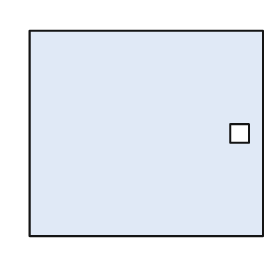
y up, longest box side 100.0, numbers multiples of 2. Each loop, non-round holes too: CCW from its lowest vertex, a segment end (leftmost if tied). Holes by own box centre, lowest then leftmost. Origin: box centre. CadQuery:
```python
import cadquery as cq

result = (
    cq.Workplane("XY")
    .moveTo(-50.0, -44.0)
    .lineTo(50.0, -44.0)
    .lineTo(50.0, 44.0)
    .lineTo(-50.0, 44.0)
    .close()
    .moveTo(36.0, -4.0)
    .lineTo(44.0, -4.0)
    .lineTo(44.0, 4.0)
    .lineTo(36.0, 4.0)
    .close()
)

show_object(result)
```